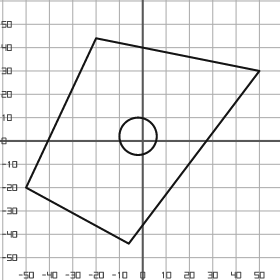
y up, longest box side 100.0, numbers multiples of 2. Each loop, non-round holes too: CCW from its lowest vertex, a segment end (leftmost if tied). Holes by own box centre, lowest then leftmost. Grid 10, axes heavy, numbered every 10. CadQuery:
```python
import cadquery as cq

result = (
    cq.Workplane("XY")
    .moveTo(-6.0, -44.0)
    .lineTo(50.0, 30.0)
    .lineTo(-20.0, 44.0)
    .lineTo(-50.0, -20.0)
    .close()
    .moveTo(-2.0, 2.0)
    .circle(8.0)
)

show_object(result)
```